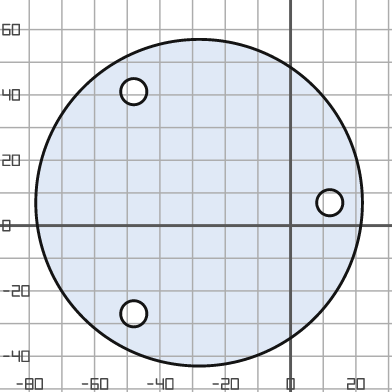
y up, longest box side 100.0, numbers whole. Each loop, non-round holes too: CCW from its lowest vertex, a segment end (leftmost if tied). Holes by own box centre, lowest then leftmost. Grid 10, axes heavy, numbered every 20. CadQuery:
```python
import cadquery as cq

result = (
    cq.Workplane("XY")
    .moveTo(-28.0, 7.0)
    .circle(50.0)
    .moveTo(-48.0, -27.0)
    .circle(4.0)
    .moveTo(12.0, 7.0)
    .circle(4.0)
    .moveTo(-48.0, 41.0)
    .circle(4.0)
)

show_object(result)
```